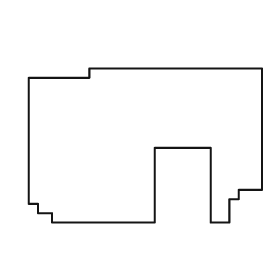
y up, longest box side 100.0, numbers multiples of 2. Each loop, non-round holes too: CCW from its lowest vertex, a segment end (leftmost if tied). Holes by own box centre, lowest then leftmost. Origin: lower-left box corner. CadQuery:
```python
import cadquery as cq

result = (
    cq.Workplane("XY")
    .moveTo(10.0, 0.0)
    .lineTo(54.0, 0.0)
    .lineTo(54.0, 32.0)
    .lineTo(78.0, 32.0)
    .lineTo(78.0, 0.0)
    .lineTo(86.0, 0.0)
    .lineTo(86.0, 10.0)
    .lineTo(90.0, 10.0)
    .lineTo(90.0, 14.0)
    .lineTo(100.0, 14.0)
    .lineTo(100.0, 66.0)
    .lineTo(26.0, 66.0)
    .lineTo(26.0, 62.0)
    .lineTo(0.0, 62.0)
    .lineTo(0.0, 8.0)
    .lineTo(4.0, 8.0)
    .lineTo(4.0, 4.0)
    .lineTo(10.0, 4.0)
    .close()
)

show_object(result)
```